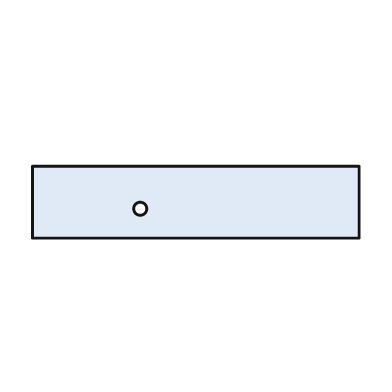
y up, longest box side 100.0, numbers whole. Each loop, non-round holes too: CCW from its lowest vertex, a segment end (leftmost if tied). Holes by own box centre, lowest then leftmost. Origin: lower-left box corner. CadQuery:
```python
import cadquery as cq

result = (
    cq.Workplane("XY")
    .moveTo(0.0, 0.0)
    .lineTo(100.0, 0.0)
    .lineTo(100.0, 22.0)
    .lineTo(0.0, 22.0)
    .close()
    .moveTo(33.0, 9.0)
    .circle(2.0)
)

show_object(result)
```